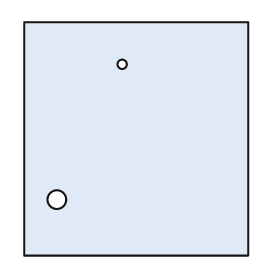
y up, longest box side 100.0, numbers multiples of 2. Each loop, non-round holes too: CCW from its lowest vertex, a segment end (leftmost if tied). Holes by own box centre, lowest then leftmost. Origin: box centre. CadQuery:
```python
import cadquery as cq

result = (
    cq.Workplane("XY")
    .moveTo(-48.0, -50.0)
    .lineTo(48.0, -50.0)
    .lineTo(48.0, 50.0)
    .lineTo(-48.0, 50.0)
    .close()
    .moveTo(-34.0, -26.0)
    .circle(4.0)
    .moveTo(-6.0, 32.0)
    .circle(2.0)
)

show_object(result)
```